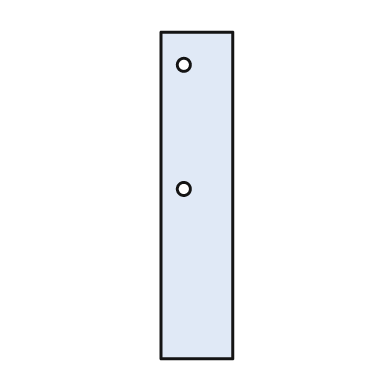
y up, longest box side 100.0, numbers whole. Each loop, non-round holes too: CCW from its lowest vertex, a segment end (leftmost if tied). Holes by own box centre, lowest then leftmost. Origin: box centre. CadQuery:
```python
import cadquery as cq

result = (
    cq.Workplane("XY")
    .moveTo(-11.0, -50.0)
    .lineTo(11.0, -50.0)
    .lineTo(11.0, 50.0)
    .lineTo(-11.0, 50.0)
    .close()
    .moveTo(-4.0, 2.0)
    .circle(2.0)
    .moveTo(-4.0, 40.0)
    .circle(2.0)
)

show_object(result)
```